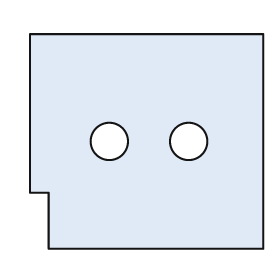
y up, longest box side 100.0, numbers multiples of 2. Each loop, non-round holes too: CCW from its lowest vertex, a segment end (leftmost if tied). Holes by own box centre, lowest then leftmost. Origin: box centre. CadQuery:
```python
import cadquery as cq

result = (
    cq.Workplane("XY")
    .moveTo(-42.0, -46.0)
    .lineTo(50.0, -46.0)
    .lineTo(50.0, 46.0)
    .lineTo(-50.0, 46.0)
    .lineTo(-50.0, -22.0)
    .lineTo(-42.0, -22.0)
    .close()
    .moveTo(-16.0, 0.0)
    .circle(8.0)
    .moveTo(18.0, 0.0)
    .circle(8.0)
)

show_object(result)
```